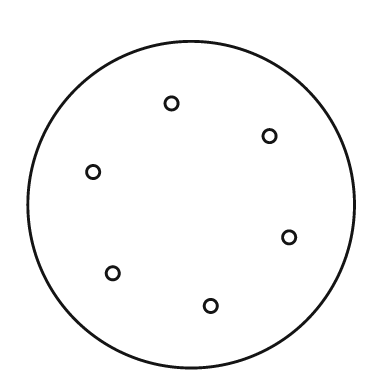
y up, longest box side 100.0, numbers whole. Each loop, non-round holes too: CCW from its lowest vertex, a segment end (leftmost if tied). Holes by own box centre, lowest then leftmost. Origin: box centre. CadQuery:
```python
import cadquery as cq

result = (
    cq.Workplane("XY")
    .moveTo(0.0, 0.0)
    .circle(50.0)
    .moveTo(6.0, -31.0)
    .circle(2.0)
    .moveTo(-24.0, -21.0)
    .circle(2.0)
    .moveTo(30.0, -10.0)
    .circle(2.0)
    .moveTo(-30.0, 10.0)
    .circle(2.0)
    .moveTo(24.0, 21.0)
    .circle(2.0)
    .moveTo(-6.0, 31.0)
    .circle(2.0)
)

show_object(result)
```